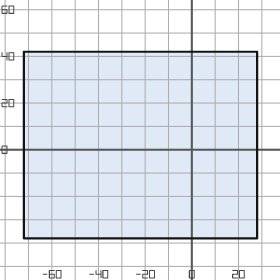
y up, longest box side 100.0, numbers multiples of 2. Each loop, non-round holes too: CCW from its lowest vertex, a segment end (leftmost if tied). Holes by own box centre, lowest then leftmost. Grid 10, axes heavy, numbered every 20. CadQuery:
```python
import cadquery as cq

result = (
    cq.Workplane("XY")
    .moveTo(-72.0, -38.0)
    .lineTo(28.0, -38.0)
    .lineTo(28.0, 42.0)
    .lineTo(-72.0, 42.0)
    .close()
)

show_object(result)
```